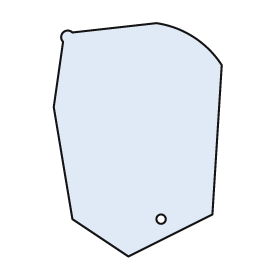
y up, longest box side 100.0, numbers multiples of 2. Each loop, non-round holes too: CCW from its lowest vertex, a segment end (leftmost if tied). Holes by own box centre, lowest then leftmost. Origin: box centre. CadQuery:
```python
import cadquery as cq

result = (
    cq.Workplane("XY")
    .moveTo(-4.0, -50.0)
    .lineTo(32.0, -32.0)
    .lineTo(36.0, 32.0)
    .threePointArc((24.0, 44.0), (8.0, 50.0))
    .lineTo(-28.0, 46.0)
    .threePointArc((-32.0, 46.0), (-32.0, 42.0))
    .lineTo(-36.0, 14.0)
    .lineTo(-28.0, -34.0)
    .close()
    .moveTo(10.0, -34.0)
    .circle(2.0)
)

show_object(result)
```